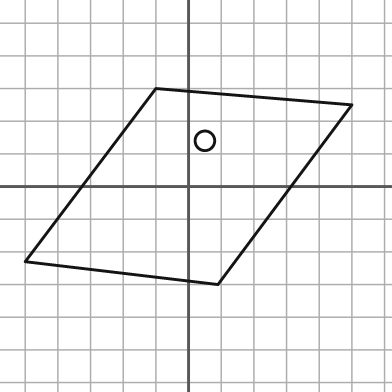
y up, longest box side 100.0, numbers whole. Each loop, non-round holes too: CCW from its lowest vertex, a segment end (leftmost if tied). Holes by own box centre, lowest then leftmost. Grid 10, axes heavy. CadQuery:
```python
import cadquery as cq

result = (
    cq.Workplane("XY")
    .moveTo(9.0, -30.0)
    .lineTo(50.0, 25.0)
    .lineTo(-10.0, 30.0)
    .lineTo(-50.0, -23.0)
    .close()
    .moveTo(5.0, 14.0)
    .circle(3.0)
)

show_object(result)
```